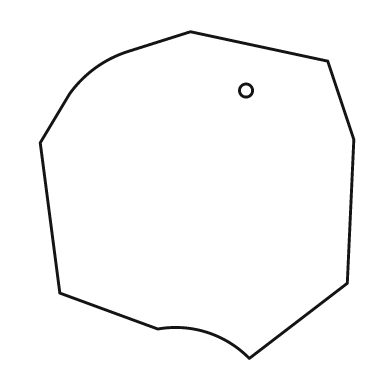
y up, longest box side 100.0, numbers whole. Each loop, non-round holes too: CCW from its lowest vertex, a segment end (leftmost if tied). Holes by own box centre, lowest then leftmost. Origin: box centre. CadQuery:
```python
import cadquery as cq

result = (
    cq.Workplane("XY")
    .moveTo(16.0, -50.0)
    .lineTo(46.0, -27.0)
    .lineTo(48.0, 17.0)
    .lineTo(40.0, 41.0)
    .lineTo(-2.0, 50.0)
    .lineTo(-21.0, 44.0)
    .threePointArc((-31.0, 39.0), (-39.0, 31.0))
    .lineTo(-48.0, 16.0)
    .lineTo(-42.0, -30.0)
    .lineTo(-12.0, -41.0)
    .threePointArc((3.0, -42.0), (16.0, -50.0))
    .close()
    .moveTo(15.0, 32.0)
    .circle(2.0)
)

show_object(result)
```